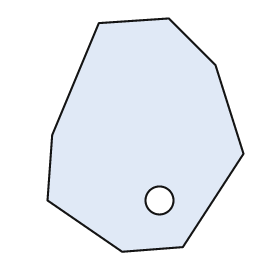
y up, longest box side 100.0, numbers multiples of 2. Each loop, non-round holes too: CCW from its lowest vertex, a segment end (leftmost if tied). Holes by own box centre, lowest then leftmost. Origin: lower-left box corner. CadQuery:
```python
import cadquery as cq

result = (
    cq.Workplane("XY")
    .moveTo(32.0, 0.0)
    .lineTo(58.0, 2.0)
    .lineTo(84.0, 42.0)
    .lineTo(72.0, 80.0)
    .lineTo(52.0, 100.0)
    .lineTo(22.0, 98.0)
    .lineTo(2.0, 50.0)
    .lineTo(0.0, 22.0)
    .close()
    .moveTo(48.0, 22.0)
    .circle(6.0)
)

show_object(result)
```